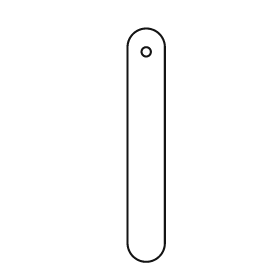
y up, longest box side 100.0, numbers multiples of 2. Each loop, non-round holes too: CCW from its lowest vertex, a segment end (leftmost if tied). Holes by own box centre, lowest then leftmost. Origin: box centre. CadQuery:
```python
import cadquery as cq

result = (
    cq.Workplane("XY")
    .moveTo(-8.0, -42.0)
    .threePointArc((0.0, -50.0), (8.0, -42.0))
    .lineTo(8.0, 42.0)
    .threePointArc((0.0, 50.0), (-8.0, 42.0))
    .close()
    .moveTo(0.0, 40.0)
    .circle(2.0)
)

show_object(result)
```